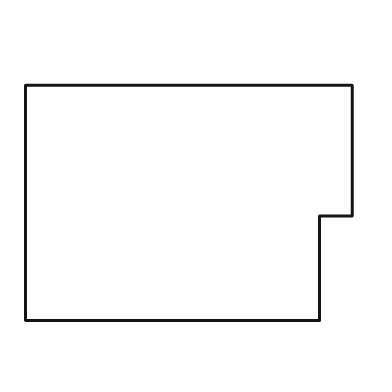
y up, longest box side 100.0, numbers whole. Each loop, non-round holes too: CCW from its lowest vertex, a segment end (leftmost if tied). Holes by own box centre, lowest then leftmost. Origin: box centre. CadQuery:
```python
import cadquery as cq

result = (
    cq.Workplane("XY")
    .moveTo(-50.0, -36.0)
    .lineTo(40.0, -36.0)
    .lineTo(40.0, -4.0)
    .lineTo(50.0, -4.0)
    .lineTo(50.0, 36.0)
    .lineTo(-50.0, 36.0)
    .close()
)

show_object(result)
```